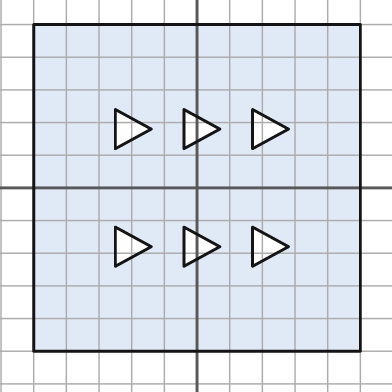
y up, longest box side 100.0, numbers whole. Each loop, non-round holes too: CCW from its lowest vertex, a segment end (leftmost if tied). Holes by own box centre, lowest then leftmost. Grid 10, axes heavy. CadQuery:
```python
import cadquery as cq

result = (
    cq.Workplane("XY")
    .moveTo(-50.0, -50.0)
    .lineTo(50.0, -50.0)
    .lineTo(50.0, 50.0)
    .lineTo(-50.0, 50.0)
    .close()
    .moveTo(-25.0, -24.0)
    .lineTo(-14.0, -18.0)
    .lineTo(-25.0, -12.0)
    .close()
    .moveTo(-4.0, -24.0)
    .lineTo(7.0, -18.0)
    .lineTo(-4.0, -12.0)
    .close()
    .moveTo(17.0, -24.0)
    .lineTo(28.0, -18.0)
    .lineTo(17.0, -12.0)
    .close()
    .moveTo(-25.0, 12.0)
    .lineTo(-14.0, 18.0)
    .lineTo(-25.0, 24.0)
    .close()
    .moveTo(-4.0, 12.0)
    .lineTo(7.0, 18.0)
    .lineTo(-4.0, 24.0)
    .close()
    .moveTo(17.0, 12.0)
    .lineTo(28.0, 18.0)
    .lineTo(17.0, 24.0)
    .close()
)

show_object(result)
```